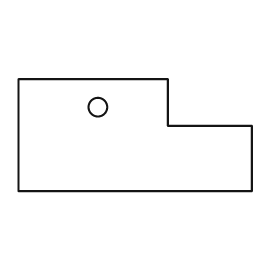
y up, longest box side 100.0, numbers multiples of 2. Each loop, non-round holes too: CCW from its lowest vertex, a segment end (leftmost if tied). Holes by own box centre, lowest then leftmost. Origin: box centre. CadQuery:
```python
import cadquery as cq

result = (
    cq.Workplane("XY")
    .moveTo(-50.0, -24.0)
    .lineTo(50.0, -24.0)
    .lineTo(50.0, 4.0)
    .lineTo(14.0, 4.0)
    .lineTo(14.0, 24.0)
    .lineTo(-50.0, 24.0)
    .close()
    .moveTo(-16.0, 12.0)
    .circle(4.0)
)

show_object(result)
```